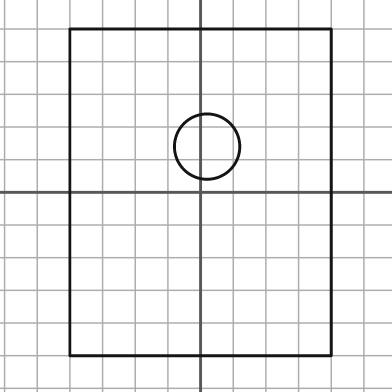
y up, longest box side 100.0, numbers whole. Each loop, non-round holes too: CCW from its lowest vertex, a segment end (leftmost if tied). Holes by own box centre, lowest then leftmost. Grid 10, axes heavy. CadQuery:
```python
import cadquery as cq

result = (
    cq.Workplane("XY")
    .moveTo(-40.0, -50.0)
    .lineTo(40.0, -50.0)
    .lineTo(40.0, 50.0)
    .lineTo(-40.0, 50.0)
    .close()
    .moveTo(2.0, 14.0)
    .circle(10.0)
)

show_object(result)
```